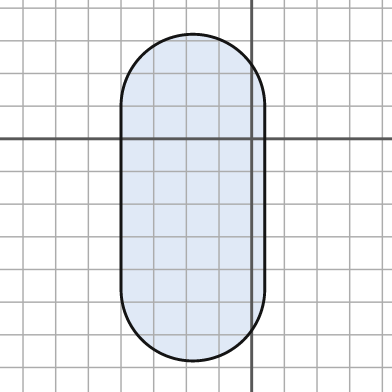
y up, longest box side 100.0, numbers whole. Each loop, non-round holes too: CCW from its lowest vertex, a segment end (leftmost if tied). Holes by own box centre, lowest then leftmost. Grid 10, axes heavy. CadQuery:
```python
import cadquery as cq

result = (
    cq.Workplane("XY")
    .moveTo(-40.0, -46.0)
    .threePointArc((-18.0, -68.0), (4.0, -46.0))
    .lineTo(4.0, 10.0)
    .threePointArc((-18.0, 32.0), (-40.0, 10.0))
    .close()
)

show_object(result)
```